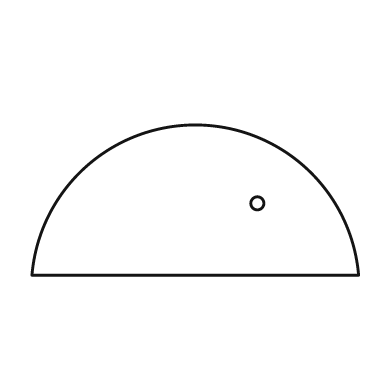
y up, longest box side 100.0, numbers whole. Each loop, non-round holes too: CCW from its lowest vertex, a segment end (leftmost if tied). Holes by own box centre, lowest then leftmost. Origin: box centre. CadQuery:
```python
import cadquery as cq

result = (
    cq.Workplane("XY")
    .moveTo(-50.0, -23.0)
    .lineTo(50.0, -23.0)
    .threePointArc((0.0, 23.0), (-50.0, -23.0))
    .close()
    .moveTo(19.0, -1.0)
    .circle(2.0)
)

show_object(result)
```